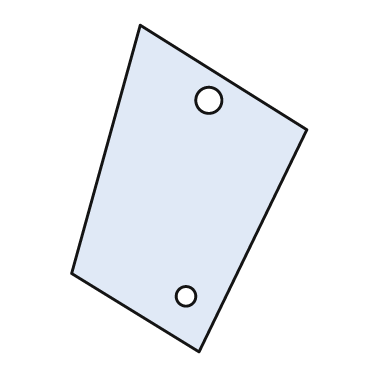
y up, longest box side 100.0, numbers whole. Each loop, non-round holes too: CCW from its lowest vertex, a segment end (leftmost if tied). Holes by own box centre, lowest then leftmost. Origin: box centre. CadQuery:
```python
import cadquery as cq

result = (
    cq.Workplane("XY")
    .moveTo(3.0, -50.0)
    .lineTo(36.0, 18.0)
    .lineTo(-15.0, 50.0)
    .lineTo(-36.0, -26.0)
    .close()
    .moveTo(-1.0, -33.0)
    .circle(3.0)
    .moveTo(6.0, 27.0)
    .circle(4.0)
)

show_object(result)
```